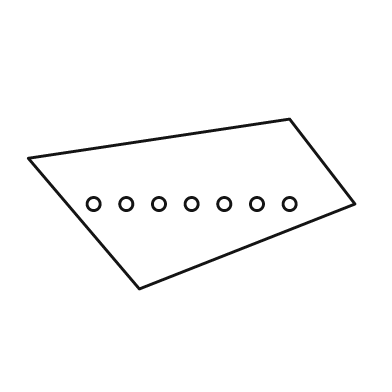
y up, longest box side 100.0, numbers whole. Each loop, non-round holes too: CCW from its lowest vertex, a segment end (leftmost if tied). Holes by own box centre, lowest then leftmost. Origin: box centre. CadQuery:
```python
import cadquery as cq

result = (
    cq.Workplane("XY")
    .moveTo(-16.0, -26.0)
    .lineTo(50.0, 0.0)
    .lineTo(30.0, 26.0)
    .lineTo(-50.0, 14.0)
    .close()
    .moveTo(-30.0, 0.0)
    .circle(2.0)
    .moveTo(-20.0, 0.0)
    .circle(2.0)
    .moveTo(-10.0, 0.0)
    .circle(2.0)
    .moveTo(0.0, 0.0)
    .circle(2.0)
    .moveTo(10.0, 0.0)
    .circle(2.0)
    .moveTo(20.0, 0.0)
    .circle(2.0)
    .moveTo(30.0, 0.0)
    .circle(2.0)
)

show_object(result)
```